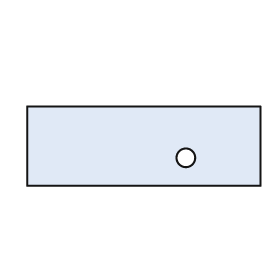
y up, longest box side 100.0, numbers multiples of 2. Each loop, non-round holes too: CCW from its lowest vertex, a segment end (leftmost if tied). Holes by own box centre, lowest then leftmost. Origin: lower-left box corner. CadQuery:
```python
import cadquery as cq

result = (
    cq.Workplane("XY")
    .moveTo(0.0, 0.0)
    .lineTo(100.0, 0.0)
    .lineTo(100.0, 34.0)
    .lineTo(0.0, 34.0)
    .close()
    .moveTo(68.0, 12.0)
    .circle(4.0)
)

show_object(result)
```